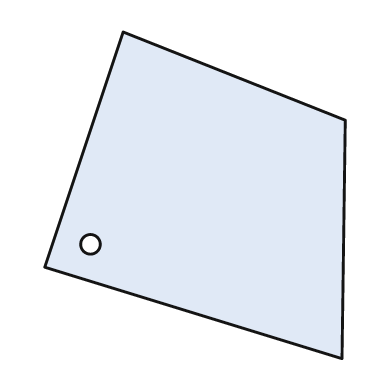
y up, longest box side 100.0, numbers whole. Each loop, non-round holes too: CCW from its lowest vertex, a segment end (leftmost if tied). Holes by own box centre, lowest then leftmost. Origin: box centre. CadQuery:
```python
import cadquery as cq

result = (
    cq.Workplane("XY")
    .moveTo(45.0, -50.0)
    .lineTo(46.0, 23.0)
    .lineTo(-22.0, 50.0)
    .lineTo(-46.0, -22.0)
    .close()
    .moveTo(-32.0, -15.0)
    .circle(3.0)
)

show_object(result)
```